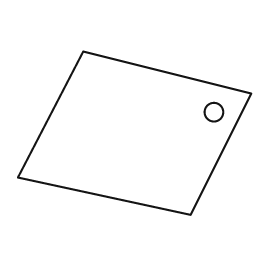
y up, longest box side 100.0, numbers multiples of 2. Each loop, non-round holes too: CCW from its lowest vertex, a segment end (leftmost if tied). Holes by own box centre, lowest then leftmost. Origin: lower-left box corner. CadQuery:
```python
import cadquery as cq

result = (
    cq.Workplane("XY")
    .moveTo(74.0, 0.0)
    .lineTo(100.0, 52.0)
    .lineTo(28.0, 70.0)
    .lineTo(0.0, 16.0)
    .close()
    .moveTo(84.0, 44.0)
    .circle(4.0)
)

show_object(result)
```